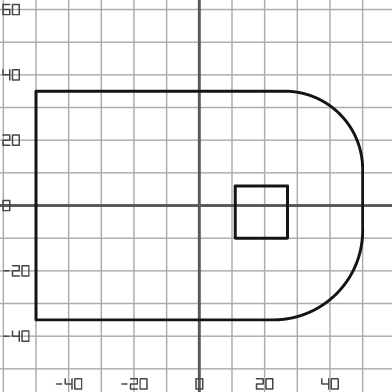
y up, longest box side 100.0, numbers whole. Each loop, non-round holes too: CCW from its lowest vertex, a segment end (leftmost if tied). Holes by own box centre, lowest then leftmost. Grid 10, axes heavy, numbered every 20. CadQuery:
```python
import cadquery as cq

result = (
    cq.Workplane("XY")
    .moveTo(-50.0, -35.0)
    .lineTo(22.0, -35.0)
    .threePointArc((42.0, -27.0), (50.0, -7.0))
    .lineTo(50.0, 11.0)
    .threePointArc((43.0, 28.0), (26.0, 35.0))
    .lineTo(-50.0, 35.0)
    .close()
    .moveTo(11.0, -10.0)
    .lineTo(27.0, -10.0)
    .lineTo(27.0, 6.0)
    .lineTo(11.0, 6.0)
    .close()
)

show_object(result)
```